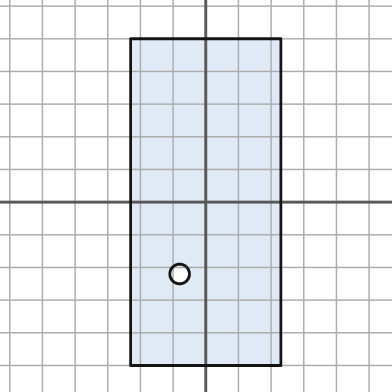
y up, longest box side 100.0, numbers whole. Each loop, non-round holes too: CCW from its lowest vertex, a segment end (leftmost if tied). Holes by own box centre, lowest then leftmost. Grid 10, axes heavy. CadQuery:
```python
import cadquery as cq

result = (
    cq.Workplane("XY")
    .moveTo(-23.0, -50.0)
    .lineTo(23.0, -50.0)
    .lineTo(23.0, 50.0)
    .lineTo(-23.0, 50.0)
    .close()
    .moveTo(-8.0, -22.0)
    .circle(3.0)
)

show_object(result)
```